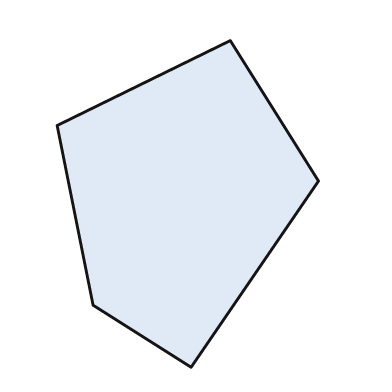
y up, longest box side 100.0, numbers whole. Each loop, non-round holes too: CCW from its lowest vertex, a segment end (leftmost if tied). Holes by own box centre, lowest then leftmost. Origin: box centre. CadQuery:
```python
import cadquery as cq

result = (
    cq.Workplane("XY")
    .moveTo(1.0, -50.0)
    .lineTo(40.0, 7.0)
    .lineTo(13.0, 50.0)
    .lineTo(-40.0, 24.0)
    .lineTo(-29.0, -31.0)
    .close()
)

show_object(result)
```